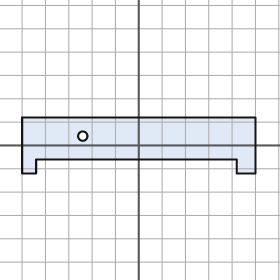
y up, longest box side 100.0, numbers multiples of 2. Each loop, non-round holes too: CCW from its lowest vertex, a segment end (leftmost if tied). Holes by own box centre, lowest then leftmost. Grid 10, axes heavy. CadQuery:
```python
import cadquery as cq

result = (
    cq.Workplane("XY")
    .moveTo(-50.0, -12.0)
    .lineTo(-44.0, -12.0)
    .lineTo(-44.0, -6.0)
    .lineTo(42.0, -6.0)
    .lineTo(42.0, -12.0)
    .lineTo(50.0, -12.0)
    .lineTo(50.0, 12.0)
    .lineTo(-50.0, 12.0)
    .close()
    .moveTo(-24.0, 4.0)
    .circle(2.0)
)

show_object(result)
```